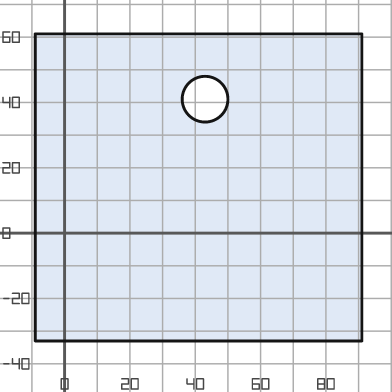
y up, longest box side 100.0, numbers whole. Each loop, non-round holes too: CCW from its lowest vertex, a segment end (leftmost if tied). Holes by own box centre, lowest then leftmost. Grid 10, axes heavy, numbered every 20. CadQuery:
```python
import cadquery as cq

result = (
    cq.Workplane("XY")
    .moveTo(-9.0, -33.0)
    .lineTo(91.0, -33.0)
    .lineTo(91.0, 61.0)
    .lineTo(-9.0, 61.0)
    .close()
    .moveTo(43.0, 41.0)
    .circle(7.0)
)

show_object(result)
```